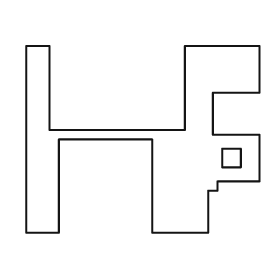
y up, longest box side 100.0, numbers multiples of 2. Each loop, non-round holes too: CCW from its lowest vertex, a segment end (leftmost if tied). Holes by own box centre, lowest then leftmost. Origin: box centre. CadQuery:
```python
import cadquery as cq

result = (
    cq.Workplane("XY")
    .moveTo(-50.0, -40.0)
    .lineTo(-36.0, -40.0)
    .lineTo(-36.0, 0.0)
    .lineTo(4.0, 0.0)
    .lineTo(4.0, -40.0)
    .lineTo(28.0, -40.0)
    .lineTo(28.0, -22.0)
    .lineTo(32.0, -22.0)
    .lineTo(32.0, -18.0)
    .lineTo(50.0, -18.0)
    .lineTo(50.0, 2.0)
    .lineTo(30.0, 2.0)
    .lineTo(30.0, 20.0)
    .lineTo(50.0, 20.0)
    .lineTo(50.0, 40.0)
    .lineTo(18.0, 40.0)
    .lineTo(18.0, 4.0)
    .lineTo(-40.0, 4.0)
    .lineTo(-40.0, 40.0)
    .lineTo(-50.0, 40.0)
    .close()
    .moveTo(34.0, -12.0)
    .lineTo(42.0, -12.0)
    .lineTo(42.0, -4.0)
    .lineTo(34.0, -4.0)
    .close()
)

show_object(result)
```